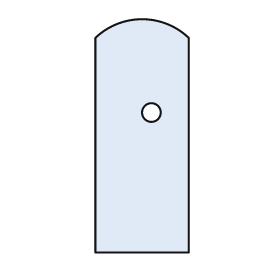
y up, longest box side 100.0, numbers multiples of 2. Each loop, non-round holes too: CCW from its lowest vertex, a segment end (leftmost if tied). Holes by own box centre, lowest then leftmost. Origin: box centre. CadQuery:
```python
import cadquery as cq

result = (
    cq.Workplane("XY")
    .moveTo(-20.0, -50.0)
    .lineTo(20.0, -50.0)
    .lineTo(20.0, 42.0)
    .threePointArc((0.0, 50.0), (-20.0, 42.0))
    .close()
    .moveTo(4.0, 10.0)
    .circle(4.0)
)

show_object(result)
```